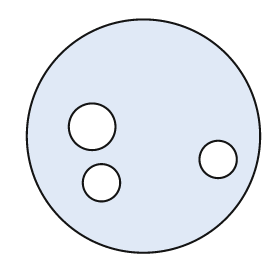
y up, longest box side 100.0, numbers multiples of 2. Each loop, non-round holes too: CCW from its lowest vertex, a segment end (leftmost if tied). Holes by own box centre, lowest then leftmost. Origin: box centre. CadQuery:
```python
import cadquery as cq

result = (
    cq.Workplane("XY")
    .moveTo(0.0, 0.0)
    .circle(50.0)
    .moveTo(-18.0, -20.0)
    .circle(8.0)
    .moveTo(32.0, -10.0)
    .circle(8.0)
    .moveTo(-22.0, 4.0)
    .circle(10.0)
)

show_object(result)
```